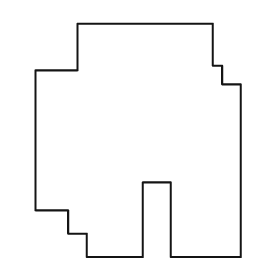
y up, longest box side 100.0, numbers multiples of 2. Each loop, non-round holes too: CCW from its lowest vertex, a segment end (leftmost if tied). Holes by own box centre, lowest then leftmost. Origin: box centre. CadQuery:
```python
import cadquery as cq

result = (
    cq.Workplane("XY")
    .moveTo(-22.0, -50.0)
    .lineTo(2.0, -50.0)
    .lineTo(2.0, -18.0)
    .lineTo(14.0, -18.0)
    .lineTo(14.0, -50.0)
    .lineTo(44.0, -50.0)
    .lineTo(44.0, 24.0)
    .lineTo(36.0, 24.0)
    .lineTo(36.0, 32.0)
    .lineTo(32.0, 32.0)
    .lineTo(32.0, 50.0)
    .lineTo(-26.0, 50.0)
    .lineTo(-26.0, 30.0)
    .lineTo(-44.0, 30.0)
    .lineTo(-44.0, -30.0)
    .lineTo(-30.0, -30.0)
    .lineTo(-30.0, -40.0)
    .lineTo(-22.0, -40.0)
    .close()
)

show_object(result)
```